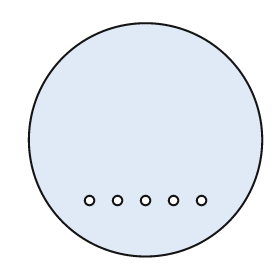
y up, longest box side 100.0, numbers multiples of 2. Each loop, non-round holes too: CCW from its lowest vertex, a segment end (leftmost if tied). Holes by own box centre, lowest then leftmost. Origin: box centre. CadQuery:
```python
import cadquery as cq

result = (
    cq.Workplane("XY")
    .moveTo(0.0, 0.0)
    .circle(50.0)
    .moveTo(-24.0, -26.0)
    .circle(2.0)
    .moveTo(-12.0, -26.0)
    .circle(2.0)
    .moveTo(0.0, -26.0)
    .circle(2.0)
    .moveTo(12.0, -26.0)
    .circle(2.0)
    .moveTo(24.0, -26.0)
    .circle(2.0)
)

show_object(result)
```